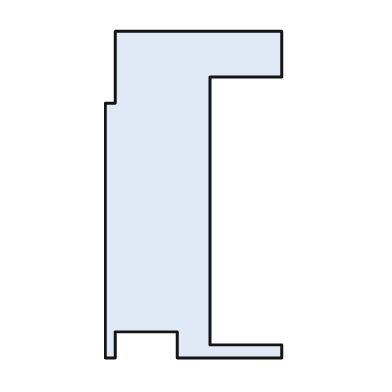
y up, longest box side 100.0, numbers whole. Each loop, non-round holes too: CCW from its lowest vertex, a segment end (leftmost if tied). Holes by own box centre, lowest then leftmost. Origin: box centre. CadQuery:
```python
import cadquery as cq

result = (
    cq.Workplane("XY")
    .moveTo(-27.0, -50.0)
    .lineTo(-24.0, -50.0)
    .lineTo(-24.0, -42.0)
    .lineTo(-5.0, -42.0)
    .lineTo(-5.0, -50.0)
    .lineTo(27.0, -50.0)
    .lineTo(27.0, -46.0)
    .lineTo(5.0, -46.0)
    .lineTo(5.0, 36.0)
    .lineTo(27.0, 36.0)
    .lineTo(27.0, 50.0)
    .lineTo(-24.0, 50.0)
    .lineTo(-24.0, 28.0)
    .lineTo(-27.0, 28.0)
    .close()
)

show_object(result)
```